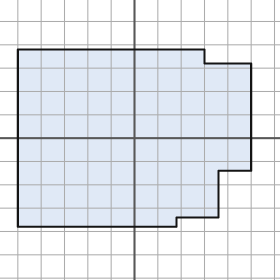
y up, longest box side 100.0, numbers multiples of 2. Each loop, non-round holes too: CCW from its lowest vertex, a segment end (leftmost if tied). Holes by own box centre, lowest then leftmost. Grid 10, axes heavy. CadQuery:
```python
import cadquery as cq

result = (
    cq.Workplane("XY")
    .moveTo(-50.0, -38.0)
    .lineTo(18.0, -38.0)
    .lineTo(18.0, -34.0)
    .lineTo(36.0, -34.0)
    .lineTo(36.0, -14.0)
    .lineTo(50.0, -14.0)
    .lineTo(50.0, 32.0)
    .lineTo(30.0, 32.0)
    .lineTo(30.0, 38.0)
    .lineTo(-50.0, 38.0)
    .close()
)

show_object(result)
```